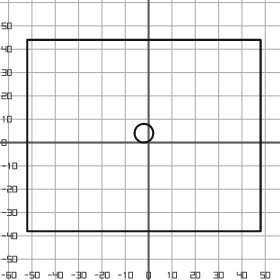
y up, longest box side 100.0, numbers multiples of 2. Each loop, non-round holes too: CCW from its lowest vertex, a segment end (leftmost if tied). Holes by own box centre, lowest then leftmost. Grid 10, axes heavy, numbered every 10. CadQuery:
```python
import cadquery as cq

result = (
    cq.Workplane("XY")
    .moveTo(-52.0, -38.0)
    .lineTo(48.0, -38.0)
    .lineTo(48.0, 44.0)
    .lineTo(-52.0, 44.0)
    .close()
    .moveTo(-2.0, 4.0)
    .circle(4.0)
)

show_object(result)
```